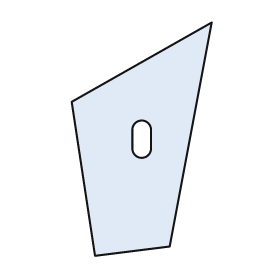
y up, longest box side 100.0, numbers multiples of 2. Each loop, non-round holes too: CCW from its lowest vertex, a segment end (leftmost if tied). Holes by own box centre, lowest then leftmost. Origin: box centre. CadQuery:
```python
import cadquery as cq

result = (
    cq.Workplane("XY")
    .moveTo(-20.0, -50.0)
    .lineTo(12.0, -46.0)
    .lineTo(30.0, 50.0)
    .lineTo(-30.0, 16.0)
    .close()
    .moveTo(-4.0, -4.0)
    .threePointArc((0.0, -8.0), (4.0, -4.0))
    .lineTo(4.0, 4.0)
    .threePointArc((0.0, 8.0), (-4.0, 4.0))
    .close()
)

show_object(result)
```